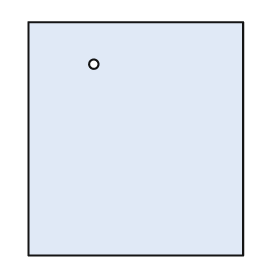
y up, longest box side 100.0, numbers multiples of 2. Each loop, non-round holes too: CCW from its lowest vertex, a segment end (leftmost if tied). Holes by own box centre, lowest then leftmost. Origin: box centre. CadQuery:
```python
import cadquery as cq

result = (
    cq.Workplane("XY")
    .moveTo(-46.0, -50.0)
    .lineTo(46.0, -50.0)
    .lineTo(46.0, 50.0)
    .lineTo(-46.0, 50.0)
    .close()
    .moveTo(-18.0, 32.0)
    .circle(2.0)
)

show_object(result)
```